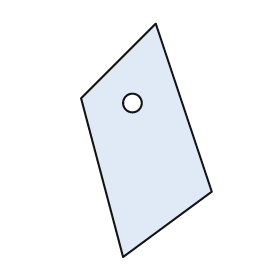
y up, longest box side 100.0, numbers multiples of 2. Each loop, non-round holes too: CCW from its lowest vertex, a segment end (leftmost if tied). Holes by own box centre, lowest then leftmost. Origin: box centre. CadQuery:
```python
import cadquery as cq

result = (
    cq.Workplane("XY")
    .moveTo(-10.0, -50.0)
    .lineTo(28.0, -22.0)
    .lineTo(4.0, 50.0)
    .lineTo(-28.0, 18.0)
    .close()
    .moveTo(-6.0, 16.0)
    .circle(4.0)
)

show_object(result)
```